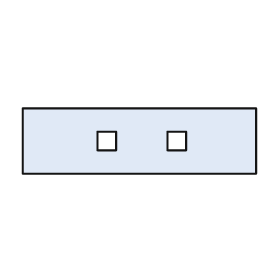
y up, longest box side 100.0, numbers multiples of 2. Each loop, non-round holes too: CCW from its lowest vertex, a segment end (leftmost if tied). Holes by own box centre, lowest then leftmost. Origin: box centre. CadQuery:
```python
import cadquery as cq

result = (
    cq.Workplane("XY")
    .moveTo(-50.0, -14.0)
    .lineTo(50.0, -14.0)
    .lineTo(50.0, 14.0)
    .lineTo(-50.0, 14.0)
    .close()
    .moveTo(-18.0, -4.0)
    .lineTo(-10.0, -4.0)
    .lineTo(-10.0, 4.0)
    .lineTo(-18.0, 4.0)
    .close()
    .moveTo(12.0, -4.0)
    .lineTo(20.0, -4.0)
    .lineTo(20.0, 4.0)
    .lineTo(12.0, 4.0)
    .close()
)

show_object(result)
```